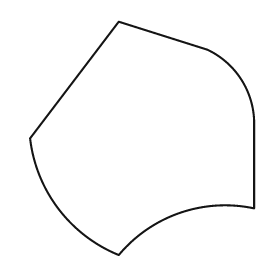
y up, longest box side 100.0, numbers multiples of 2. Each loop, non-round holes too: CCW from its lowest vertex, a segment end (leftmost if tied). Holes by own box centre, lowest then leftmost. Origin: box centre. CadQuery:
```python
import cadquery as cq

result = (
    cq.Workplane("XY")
    .moveTo(-10.0, -50.0)
    .threePointArc((16.0, -32.0), (48.0, -30.0))
    .lineTo(48.0, 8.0)
    .threePointArc((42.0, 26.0), (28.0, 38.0))
    .lineTo(-10.0, 50.0)
    .lineTo(-48.0, 0.0)
    .threePointArc((-36.0, -30.0), (-10.0, -50.0))
    .close()
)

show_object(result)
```